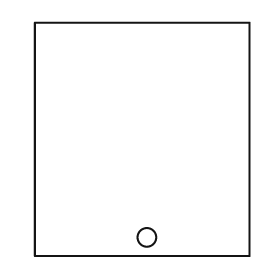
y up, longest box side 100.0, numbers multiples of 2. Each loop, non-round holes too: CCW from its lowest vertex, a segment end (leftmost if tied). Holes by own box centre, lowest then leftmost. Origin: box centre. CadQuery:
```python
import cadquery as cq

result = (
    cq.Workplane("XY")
    .moveTo(-46.0, -50.0)
    .lineTo(46.0, -50.0)
    .lineTo(46.0, 50.0)
    .lineTo(-46.0, 50.0)
    .close()
    .moveTo(2.0, -42.0)
    .circle(4.0)
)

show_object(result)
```